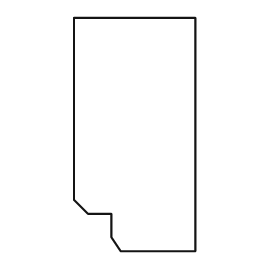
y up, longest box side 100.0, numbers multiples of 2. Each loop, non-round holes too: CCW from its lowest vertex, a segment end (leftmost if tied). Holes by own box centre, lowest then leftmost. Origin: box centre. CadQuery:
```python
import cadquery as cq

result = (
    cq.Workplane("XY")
    .moveTo(-6.0, -50.0)
    .lineTo(26.0, -50.0)
    .lineTo(26.0, 50.0)
    .lineTo(-26.0, 50.0)
    .lineTo(-26.0, -28.0)
    .lineTo(-20.0, -34.0)
    .lineTo(-10.0, -34.0)
    .lineTo(-10.0, -44.0)
    .close()
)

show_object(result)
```